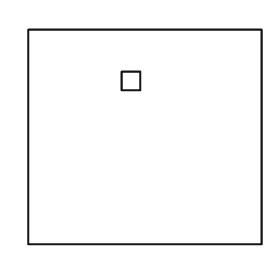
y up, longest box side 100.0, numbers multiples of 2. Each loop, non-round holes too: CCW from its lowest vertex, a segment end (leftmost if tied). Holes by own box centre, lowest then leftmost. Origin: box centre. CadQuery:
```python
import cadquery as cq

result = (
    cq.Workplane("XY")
    .moveTo(-50.0, -46.0)
    .lineTo(50.0, -46.0)
    .lineTo(50.0, 46.0)
    .lineTo(-50.0, 46.0)
    .close()
    .moveTo(-10.0, 20.0)
    .lineTo(-2.0, 20.0)
    .lineTo(-2.0, 28.0)
    .lineTo(-10.0, 28.0)
    .close()
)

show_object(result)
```